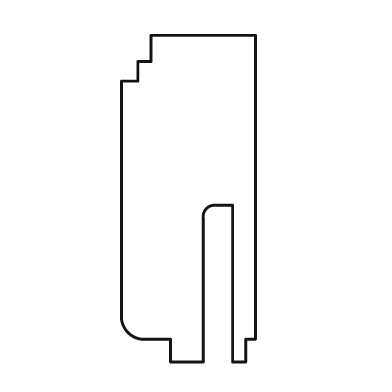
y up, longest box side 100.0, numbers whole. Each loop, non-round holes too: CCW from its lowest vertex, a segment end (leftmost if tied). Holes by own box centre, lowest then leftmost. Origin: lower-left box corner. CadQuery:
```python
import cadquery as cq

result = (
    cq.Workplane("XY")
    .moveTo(15.0, 0.0)
    .lineTo(25.0, 0.0)
    .lineTo(25.0, 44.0)
    .threePointArc((26.0, 47.0), (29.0, 48.0))
    .lineTo(34.0, 48.0)
    .lineTo(34.0, 0.0)
    .lineTo(38.0, 0.0)
    .lineTo(38.0, 7.0)
    .lineTo(41.0, 7.0)
    .lineTo(41.0, 100.0)
    .lineTo(9.0, 100.0)
    .lineTo(9.0, 92.0)
    .lineTo(5.0, 92.0)
    .lineTo(5.0, 86.0)
    .lineTo(0.0, 86.0)
    .lineTo(0.0, 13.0)
    .threePointArc((2.0, 9.0), (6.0, 7.0))
    .lineTo(15.0, 7.0)
    .close()
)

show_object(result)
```